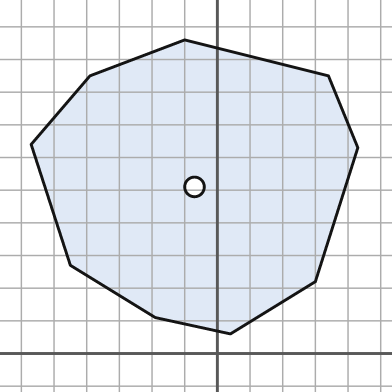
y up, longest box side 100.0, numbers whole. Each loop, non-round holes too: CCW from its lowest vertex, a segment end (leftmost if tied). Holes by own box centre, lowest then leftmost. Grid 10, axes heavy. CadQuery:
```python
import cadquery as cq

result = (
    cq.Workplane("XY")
    .moveTo(4.0, 6.0)
    .lineTo(30.0, 22.0)
    .lineTo(43.0, 63.0)
    .lineTo(34.0, 85.0)
    .lineTo(-10.0, 96.0)
    .lineTo(-39.0, 85.0)
    .lineTo(-57.0, 64.0)
    .lineTo(-45.0, 27.0)
    .lineTo(-19.0, 11.0)
    .close()
    .moveTo(-7.0, 51.0)
    .circle(3.0)
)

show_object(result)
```